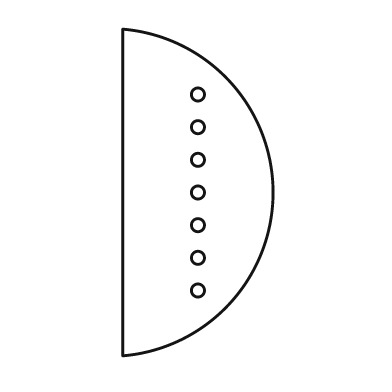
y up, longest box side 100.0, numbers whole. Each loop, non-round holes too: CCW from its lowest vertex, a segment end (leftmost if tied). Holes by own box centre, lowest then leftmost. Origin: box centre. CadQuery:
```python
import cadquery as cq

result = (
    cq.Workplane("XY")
    .moveTo(-23.0, -50.0)
    .threePointArc((23.0, 0.0), (-23.0, 50.0))
    .close()
    .moveTo(0.0, -30.0)
    .circle(2.0)
    .moveTo(0.0, -20.0)
    .circle(2.0)
    .moveTo(0.0, -10.0)
    .circle(2.0)
    .moveTo(0.0, 0.0)
    .circle(2.0)
    .moveTo(0.0, 10.0)
    .circle(2.0)
    .moveTo(0.0, 20.0)
    .circle(2.0)
    .moveTo(0.0, 30.0)
    .circle(2.0)
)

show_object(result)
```